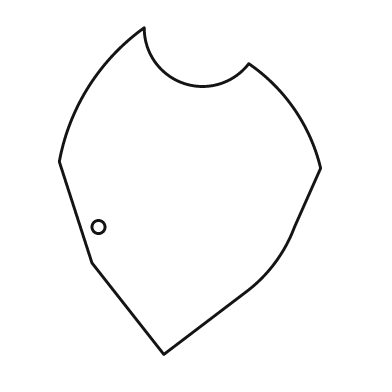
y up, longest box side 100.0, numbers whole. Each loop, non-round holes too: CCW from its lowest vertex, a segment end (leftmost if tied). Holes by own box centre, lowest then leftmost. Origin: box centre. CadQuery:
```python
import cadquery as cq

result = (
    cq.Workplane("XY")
    .moveTo(-8.0, -50.0)
    .lineTo(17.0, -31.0)
    .threePointArc((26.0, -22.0), (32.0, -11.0))
    .lineTo(40.0, 7.0)
    .threePointArc((32.0, 25.0), (18.0, 39.0))
    .threePointArc((-2.0, 33.0), (-14.0, 50.0))
    .threePointArc((-31.0, 32.0), (-40.0, 9.0))
    .lineTo(-30.0, -22.0)
    .close()
    .moveTo(-28.0, -11.0)
    .circle(2.0)
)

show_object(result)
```